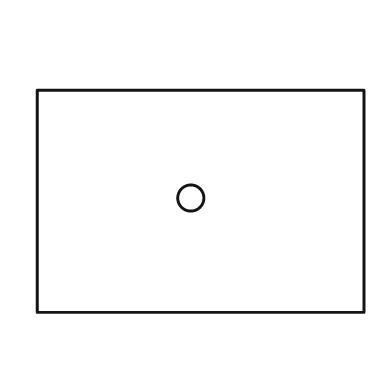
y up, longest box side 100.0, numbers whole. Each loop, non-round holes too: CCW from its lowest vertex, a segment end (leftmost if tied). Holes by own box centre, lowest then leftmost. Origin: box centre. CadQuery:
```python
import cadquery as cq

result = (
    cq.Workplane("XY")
    .moveTo(-50.0, -34.0)
    .lineTo(50.0, -34.0)
    .lineTo(50.0, 34.0)
    .lineTo(-50.0, 34.0)
    .close()
    .moveTo(-3.0, 1.0)
    .circle(4.0)
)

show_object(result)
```